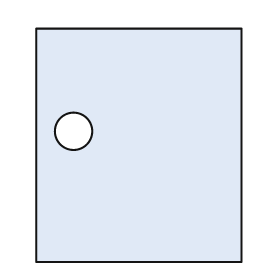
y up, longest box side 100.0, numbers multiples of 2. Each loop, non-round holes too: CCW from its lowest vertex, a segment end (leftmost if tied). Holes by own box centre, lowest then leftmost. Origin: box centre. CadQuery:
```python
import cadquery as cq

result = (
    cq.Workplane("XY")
    .moveTo(-44.0, -50.0)
    .lineTo(44.0, -50.0)
    .lineTo(44.0, 50.0)
    .lineTo(-44.0, 50.0)
    .close()
    .moveTo(-28.0, 6.0)
    .circle(8.0)
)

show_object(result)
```